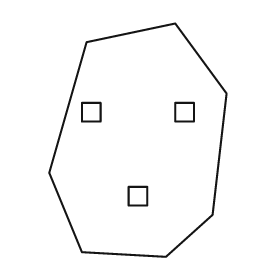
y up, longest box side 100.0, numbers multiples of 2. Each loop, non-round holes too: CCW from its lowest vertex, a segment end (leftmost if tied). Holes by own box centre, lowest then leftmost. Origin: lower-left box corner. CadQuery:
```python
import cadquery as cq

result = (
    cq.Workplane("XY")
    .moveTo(50.0, 0.0)
    .lineTo(70.0, 18.0)
    .lineTo(76.0, 70.0)
    .lineTo(54.0, 100.0)
    .lineTo(16.0, 92.0)
    .lineTo(0.0, 36.0)
    .lineTo(14.0, 2.0)
    .close()
    .moveTo(34.0, 22.0)
    .lineTo(42.0, 22.0)
    .lineTo(42.0, 30.0)
    .lineTo(34.0, 30.0)
    .close()
    .moveTo(14.0, 58.0)
    .lineTo(22.0, 58.0)
    .lineTo(22.0, 66.0)
    .lineTo(14.0, 66.0)
    .close()
    .moveTo(54.0, 58.0)
    .lineTo(62.0, 58.0)
    .lineTo(62.0, 66.0)
    .lineTo(54.0, 66.0)
    .close()
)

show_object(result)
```